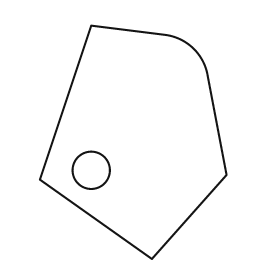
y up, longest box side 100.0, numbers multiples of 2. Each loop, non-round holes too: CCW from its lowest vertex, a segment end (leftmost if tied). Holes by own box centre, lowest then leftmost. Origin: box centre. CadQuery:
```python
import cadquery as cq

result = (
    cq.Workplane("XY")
    .moveTo(8.0, -50.0)
    .lineTo(40.0, -14.0)
    .lineTo(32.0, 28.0)
    .threePointArc((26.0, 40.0), (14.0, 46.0))
    .lineTo(-18.0, 50.0)
    .lineTo(-40.0, -16.0)
    .close()
    .moveTo(-18.0, -12.0)
    .circle(8.0)
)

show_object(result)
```